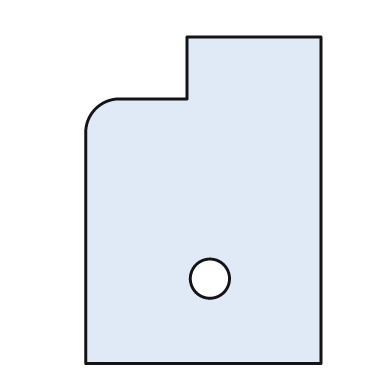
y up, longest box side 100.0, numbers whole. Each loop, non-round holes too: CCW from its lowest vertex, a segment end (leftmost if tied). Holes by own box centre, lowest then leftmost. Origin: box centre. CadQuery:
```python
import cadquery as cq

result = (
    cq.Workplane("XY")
    .moveTo(-36.0, -50.0)
    .lineTo(36.0, -50.0)
    .lineTo(36.0, 50.0)
    .lineTo(-5.0, 50.0)
    .lineTo(-5.0, 31.0)
    .lineTo(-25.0, 31.0)
    .threePointArc((-33.0, 28.0), (-36.0, 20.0))
    .close()
    .moveTo(2.0, -24.0)
    .circle(6.0)
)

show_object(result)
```